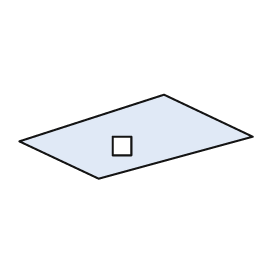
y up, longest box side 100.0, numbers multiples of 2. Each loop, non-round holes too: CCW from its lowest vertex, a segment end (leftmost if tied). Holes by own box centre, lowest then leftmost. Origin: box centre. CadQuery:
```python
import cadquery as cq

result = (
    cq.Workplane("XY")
    .moveTo(-16.0, -18.0)
    .lineTo(50.0, 0.0)
    .lineTo(12.0, 18.0)
    .lineTo(-50.0, -2.0)
    .close()
    .moveTo(-10.0, -8.0)
    .lineTo(-2.0, -8.0)
    .lineTo(-2.0, 0.0)
    .lineTo(-10.0, 0.0)
    .close()
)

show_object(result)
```